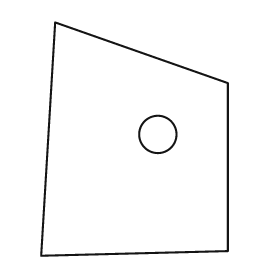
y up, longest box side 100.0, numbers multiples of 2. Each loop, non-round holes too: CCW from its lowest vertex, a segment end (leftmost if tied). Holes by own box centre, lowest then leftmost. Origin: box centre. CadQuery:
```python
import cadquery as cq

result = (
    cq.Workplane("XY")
    .moveTo(-40.0, -50.0)
    .lineTo(40.0, -48.0)
    .lineTo(40.0, 24.0)
    .lineTo(-34.0, 50.0)
    .close()
    .moveTo(10.0, 2.0)
    .circle(8.0)
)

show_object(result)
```